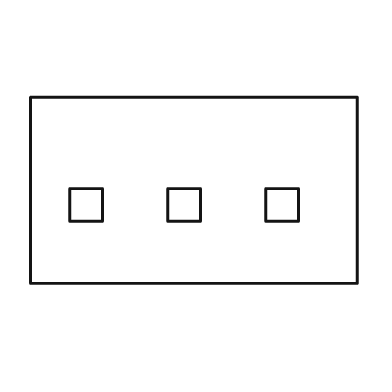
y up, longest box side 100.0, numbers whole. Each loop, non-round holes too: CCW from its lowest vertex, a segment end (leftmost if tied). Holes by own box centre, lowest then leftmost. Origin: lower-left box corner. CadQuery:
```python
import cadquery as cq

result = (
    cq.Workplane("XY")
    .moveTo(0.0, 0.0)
    .lineTo(100.0, 0.0)
    .lineTo(100.0, 57.0)
    .lineTo(0.0, 57.0)
    .close()
    .moveTo(12.0, 19.0)
    .lineTo(22.0, 19.0)
    .lineTo(22.0, 29.0)
    .lineTo(12.0, 29.0)
    .close()
    .moveTo(42.0, 19.0)
    .lineTo(52.0, 19.0)
    .lineTo(52.0, 29.0)
    .lineTo(42.0, 29.0)
    .close()
    .moveTo(72.0, 19.0)
    .lineTo(82.0, 19.0)
    .lineTo(82.0, 29.0)
    .lineTo(72.0, 29.0)
    .close()
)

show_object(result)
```